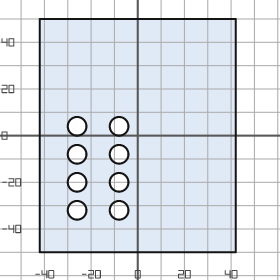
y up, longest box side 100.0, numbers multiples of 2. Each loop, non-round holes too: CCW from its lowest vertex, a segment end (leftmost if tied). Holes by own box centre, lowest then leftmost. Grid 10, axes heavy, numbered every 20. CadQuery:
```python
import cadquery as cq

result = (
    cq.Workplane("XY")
    .moveTo(-42.0, -50.0)
    .lineTo(42.0, -50.0)
    .lineTo(42.0, 50.0)
    .lineTo(-42.0, 50.0)
    .close()
    .moveTo(-26.0, -32.0)
    .circle(4.0)
    .moveTo(-8.0, -32.0)
    .circle(4.0)
    .moveTo(-26.0, -20.0)
    .circle(4.0)
    .moveTo(-8.0, -20.0)
    .circle(4.0)
    .moveTo(-26.0, -8.0)
    .circle(4.0)
    .moveTo(-8.0, -8.0)
    .circle(4.0)
    .moveTo(-26.0, 4.0)
    .circle(4.0)
    .moveTo(-8.0, 4.0)
    .circle(4.0)
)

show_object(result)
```